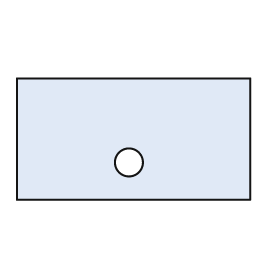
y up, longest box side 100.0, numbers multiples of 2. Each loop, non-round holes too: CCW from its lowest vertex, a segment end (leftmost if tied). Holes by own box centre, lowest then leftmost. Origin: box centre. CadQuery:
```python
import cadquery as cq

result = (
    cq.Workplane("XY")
    .moveTo(-50.0, -26.0)
    .lineTo(50.0, -26.0)
    .lineTo(50.0, 26.0)
    .lineTo(-50.0, 26.0)
    .close()
    .moveTo(-2.0, -10.0)
    .circle(6.0)
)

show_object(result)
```